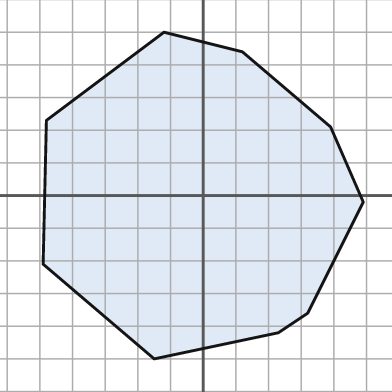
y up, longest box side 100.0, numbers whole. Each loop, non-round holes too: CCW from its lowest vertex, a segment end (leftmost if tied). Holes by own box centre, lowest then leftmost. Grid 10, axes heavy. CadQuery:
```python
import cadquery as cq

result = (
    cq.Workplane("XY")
    .moveTo(-15.0, -50.0)
    .lineTo(23.0, -42.0)
    .lineTo(32.0, -36.0)
    .lineTo(49.0, -2.0)
    .lineTo(39.0, 21.0)
    .lineTo(12.0, 44.0)
    .lineTo(-12.0, 50.0)
    .lineTo(-48.0, 23.0)
    .lineTo(-49.0, -21.0)
    .close()
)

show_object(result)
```